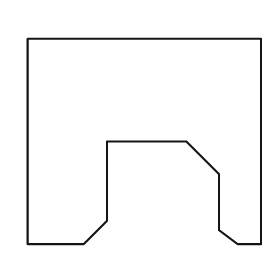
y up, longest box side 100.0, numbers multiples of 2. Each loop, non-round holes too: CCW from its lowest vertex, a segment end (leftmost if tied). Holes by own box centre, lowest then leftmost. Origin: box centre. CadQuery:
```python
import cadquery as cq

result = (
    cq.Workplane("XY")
    .moveTo(-50.0, -44.0)
    .lineTo(-26.0, -44.0)
    .lineTo(-16.0, -34.0)
    .lineTo(-16.0, 0.0)
    .lineTo(18.0, 0.0)
    .lineTo(32.0, -14.0)
    .lineTo(32.0, -38.0)
    .lineTo(40.0, -44.0)
    .lineTo(50.0, -44.0)
    .lineTo(50.0, 44.0)
    .lineTo(-50.0, 44.0)
    .close()
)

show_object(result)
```